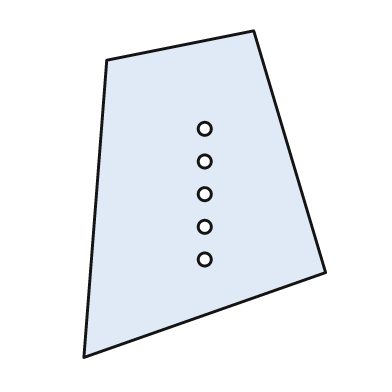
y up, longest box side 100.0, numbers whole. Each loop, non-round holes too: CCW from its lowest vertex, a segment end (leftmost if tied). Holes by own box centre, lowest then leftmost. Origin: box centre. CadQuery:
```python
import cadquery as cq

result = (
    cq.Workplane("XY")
    .moveTo(-37.0, -50.0)
    .lineTo(37.0, -24.0)
    .lineTo(15.0, 50.0)
    .lineTo(-30.0, 41.0)
    .close()
    .moveTo(0.0, -20.0)
    .circle(2.0)
    .moveTo(0.0, -10.0)
    .circle(2.0)
    .moveTo(0.0, 0.0)
    .circle(2.0)
    .moveTo(0.0, 10.0)
    .circle(2.0)
    .moveTo(0.0, 20.0)
    .circle(2.0)
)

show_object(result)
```